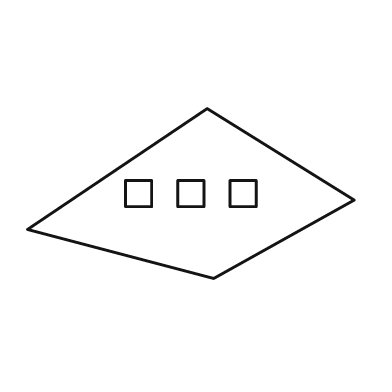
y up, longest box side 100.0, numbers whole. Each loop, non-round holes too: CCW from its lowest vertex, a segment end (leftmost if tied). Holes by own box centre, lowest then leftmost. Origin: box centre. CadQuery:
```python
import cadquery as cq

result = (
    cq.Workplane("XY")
    .moveTo(7.0, -26.0)
    .lineTo(50.0, -2.0)
    .lineTo(5.0, 26.0)
    .lineTo(-50.0, -11.0)
    .close()
    .moveTo(-20.0, -4.0)
    .lineTo(-12.0, -4.0)
    .lineTo(-12.0, 4.0)
    .lineTo(-20.0, 4.0)
    .close()
    .moveTo(-4.0, -4.0)
    .lineTo(4.0, -4.0)
    .lineTo(4.0, 4.0)
    .lineTo(-4.0, 4.0)
    .close()
    .moveTo(12.0, -4.0)
    .lineTo(20.0, -4.0)
    .lineTo(20.0, 4.0)
    .lineTo(12.0, 4.0)
    .close()
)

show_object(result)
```